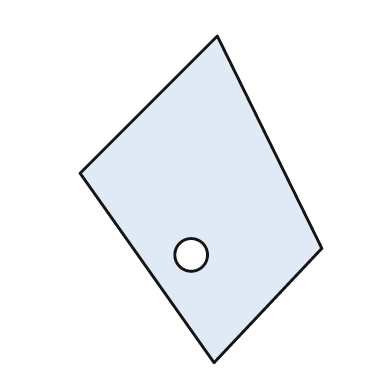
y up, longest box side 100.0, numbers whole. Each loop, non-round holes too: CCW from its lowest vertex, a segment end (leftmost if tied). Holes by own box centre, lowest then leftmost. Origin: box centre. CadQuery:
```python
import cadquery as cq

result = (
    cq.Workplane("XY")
    .moveTo(4.0, -50.0)
    .lineTo(37.0, -15.0)
    .lineTo(5.0, 50.0)
    .lineTo(-37.0, 8.0)
    .close()
    .moveTo(-3.0, -17.0)
    .circle(5.0)
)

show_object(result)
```